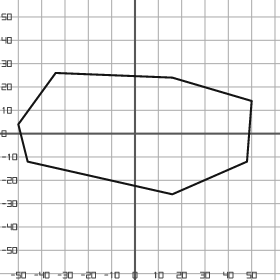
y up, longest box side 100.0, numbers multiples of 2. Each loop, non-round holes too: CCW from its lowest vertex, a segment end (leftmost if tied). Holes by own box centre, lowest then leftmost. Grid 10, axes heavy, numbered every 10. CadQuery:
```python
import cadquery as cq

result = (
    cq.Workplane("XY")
    .moveTo(16.0, -26.0)
    .lineTo(48.0, -12.0)
    .lineTo(50.0, 14.0)
    .lineTo(16.0, 24.0)
    .lineTo(-34.0, 26.0)
    .lineTo(-50.0, 4.0)
    .lineTo(-46.0, -12.0)
    .close()
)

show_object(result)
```